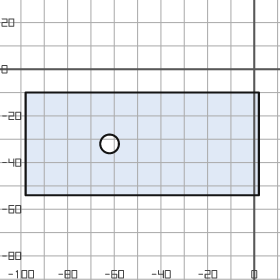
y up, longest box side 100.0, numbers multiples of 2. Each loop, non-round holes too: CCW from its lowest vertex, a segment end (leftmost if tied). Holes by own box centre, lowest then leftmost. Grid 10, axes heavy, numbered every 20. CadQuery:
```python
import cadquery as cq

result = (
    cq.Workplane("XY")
    .moveTo(-98.0, -54.0)
    .lineTo(2.0, -54.0)
    .lineTo(2.0, -10.0)
    .lineTo(-98.0, -10.0)
    .close()
    .moveTo(-62.0, -32.0)
    .circle(4.0)
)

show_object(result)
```